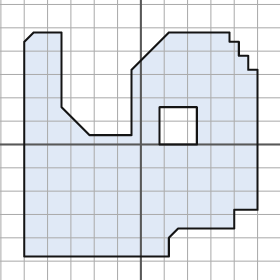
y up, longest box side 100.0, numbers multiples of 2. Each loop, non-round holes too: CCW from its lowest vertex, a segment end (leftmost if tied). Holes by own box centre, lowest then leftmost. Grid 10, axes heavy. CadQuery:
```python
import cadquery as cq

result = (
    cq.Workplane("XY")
    .moveTo(-50.0, -48.0)
    .lineTo(12.0, -48.0)
    .lineTo(12.0, -40.0)
    .lineTo(16.0, -36.0)
    .lineTo(40.0, -36.0)
    .lineTo(40.0, -28.0)
    .lineTo(50.0, -28.0)
    .lineTo(50.0, 32.0)
    .lineTo(46.0, 32.0)
    .lineTo(46.0, 38.0)
    .lineTo(42.0, 38.0)
    .lineTo(42.0, 44.0)
    .lineTo(38.0, 44.0)
    .lineTo(38.0, 48.0)
    .lineTo(12.0, 48.0)
    .lineTo(-4.0, 32.0)
    .lineTo(-4.0, 4.0)
    .lineTo(-22.0, 4.0)
    .lineTo(-34.0, 16.0)
    .lineTo(-34.0, 48.0)
    .lineTo(-46.0, 48.0)
    .lineTo(-50.0, 44.0)
    .close()
    .moveTo(8.0, 0.0)
    .lineTo(24.0, 0.0)
    .lineTo(24.0, 16.0)
    .lineTo(8.0, 16.0)
    .close()
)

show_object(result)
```